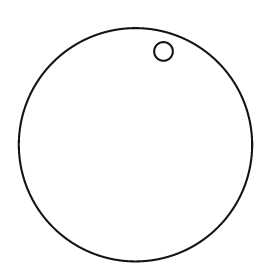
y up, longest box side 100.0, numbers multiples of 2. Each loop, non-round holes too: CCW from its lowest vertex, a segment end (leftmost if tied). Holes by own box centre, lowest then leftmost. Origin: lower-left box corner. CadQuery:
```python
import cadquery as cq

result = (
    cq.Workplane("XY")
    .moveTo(50.0, 50.0)
    .circle(50.0)
    .moveTo(62.0, 90.0)
    .circle(4.0)
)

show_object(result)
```